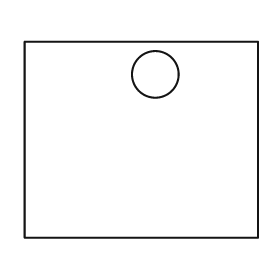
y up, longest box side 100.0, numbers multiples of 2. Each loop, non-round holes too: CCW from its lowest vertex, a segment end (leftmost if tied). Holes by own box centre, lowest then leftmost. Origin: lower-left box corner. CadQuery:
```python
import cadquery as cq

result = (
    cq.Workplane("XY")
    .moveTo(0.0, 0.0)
    .lineTo(100.0, 0.0)
    .lineTo(100.0, 84.0)
    .lineTo(0.0, 84.0)
    .close()
    .moveTo(56.0, 70.0)
    .circle(10.0)
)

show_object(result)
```